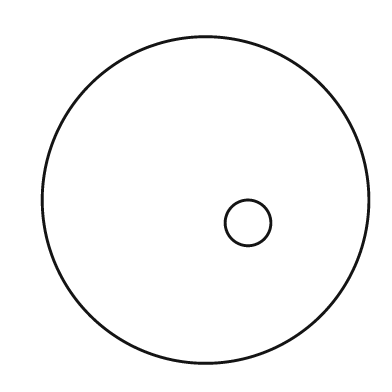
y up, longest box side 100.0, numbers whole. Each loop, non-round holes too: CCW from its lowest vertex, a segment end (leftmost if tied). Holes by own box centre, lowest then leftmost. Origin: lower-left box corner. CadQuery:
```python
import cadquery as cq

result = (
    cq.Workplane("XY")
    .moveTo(50.0, 50.0)
    .circle(50.0)
    .moveTo(63.0, 43.0)
    .circle(7.0)
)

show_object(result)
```